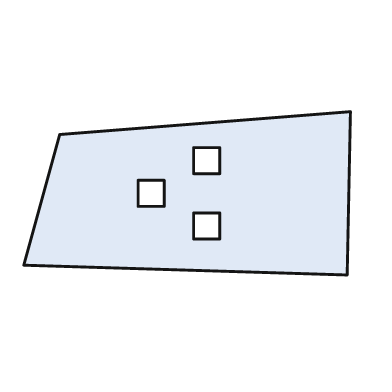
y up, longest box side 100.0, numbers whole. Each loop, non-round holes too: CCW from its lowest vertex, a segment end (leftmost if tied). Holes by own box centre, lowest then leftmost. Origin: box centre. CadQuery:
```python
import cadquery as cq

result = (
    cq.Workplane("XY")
    .moveTo(49.0, -25.0)
    .lineTo(50.0, 25.0)
    .lineTo(-39.0, 18.0)
    .lineTo(-50.0, -22.0)
    .close()
    .moveTo(2.0, -14.0)
    .lineTo(10.0, -14.0)
    .lineTo(10.0, -6.0)
    .lineTo(2.0, -6.0)
    .close()
    .moveTo(-15.0, -4.0)
    .lineTo(-7.0, -4.0)
    .lineTo(-7.0, 4.0)
    .lineTo(-15.0, 4.0)
    .close()
    .moveTo(2.0, 6.0)
    .lineTo(10.0, 6.0)
    .lineTo(10.0, 14.0)
    .lineTo(2.0, 14.0)
    .close()
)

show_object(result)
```